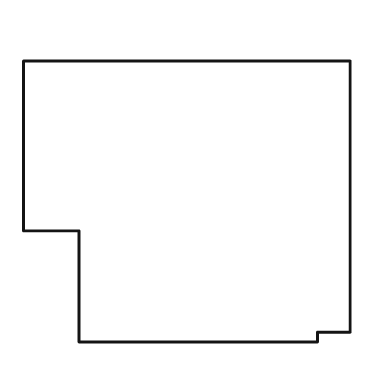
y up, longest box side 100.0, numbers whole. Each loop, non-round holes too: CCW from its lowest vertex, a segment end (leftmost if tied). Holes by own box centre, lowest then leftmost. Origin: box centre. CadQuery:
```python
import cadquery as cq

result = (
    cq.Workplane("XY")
    .moveTo(-33.0, -43.0)
    .lineTo(40.0, -43.0)
    .lineTo(40.0, -40.0)
    .lineTo(50.0, -40.0)
    .lineTo(50.0, 43.0)
    .lineTo(-50.0, 43.0)
    .lineTo(-50.0, -9.0)
    .lineTo(-33.0, -9.0)
    .close()
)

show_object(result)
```